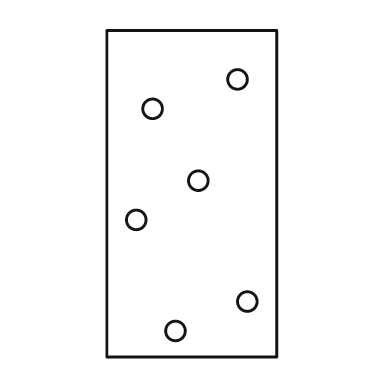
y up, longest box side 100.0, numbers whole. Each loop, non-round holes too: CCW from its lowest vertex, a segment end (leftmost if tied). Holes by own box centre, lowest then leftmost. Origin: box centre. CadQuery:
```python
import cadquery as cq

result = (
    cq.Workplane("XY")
    .moveTo(-26.0, -50.0)
    .lineTo(26.0, -50.0)
    .lineTo(26.0, 50.0)
    .lineTo(-26.0, 50.0)
    .close()
    .moveTo(-5.0, -42.0)
    .circle(3.0)
    .moveTo(17.0, -33.0)
    .circle(3.0)
    .moveTo(-17.0, -8.0)
    .circle(3.0)
    .moveTo(2.0, 4.0)
    .circle(3.0)
    .moveTo(-12.0, 26.0)
    .circle(3.0)
    .moveTo(14.0, 35.0)
    .circle(3.0)
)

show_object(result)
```